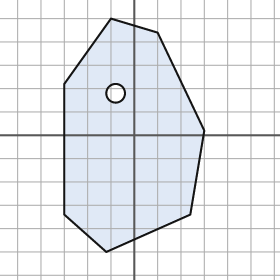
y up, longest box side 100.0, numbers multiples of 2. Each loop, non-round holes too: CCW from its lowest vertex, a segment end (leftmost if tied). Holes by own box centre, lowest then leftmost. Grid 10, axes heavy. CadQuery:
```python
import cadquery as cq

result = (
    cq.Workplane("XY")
    .moveTo(-12.0, -50.0)
    .lineTo(24.0, -34.0)
    .lineTo(30.0, 2.0)
    .lineTo(10.0, 44.0)
    .lineTo(-10.0, 50.0)
    .lineTo(-30.0, 22.0)
    .lineTo(-30.0, -34.0)
    .close()
    .moveTo(-8.0, 18.0)
    .circle(4.0)
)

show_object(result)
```